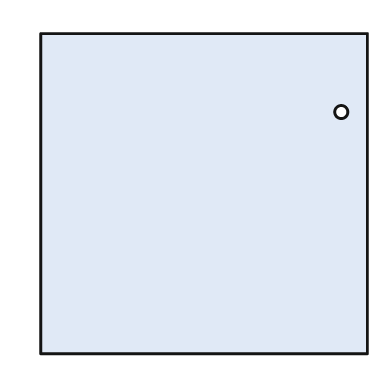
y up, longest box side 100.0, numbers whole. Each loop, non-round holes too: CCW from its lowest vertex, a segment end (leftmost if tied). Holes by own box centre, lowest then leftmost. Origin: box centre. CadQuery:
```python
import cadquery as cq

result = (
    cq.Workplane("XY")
    .moveTo(-50.0, -49.0)
    .lineTo(50.0, -49.0)
    .lineTo(50.0, 49.0)
    .lineTo(-50.0, 49.0)
    .close()
    .moveTo(42.0, 25.0)
    .circle(2.0)
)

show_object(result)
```